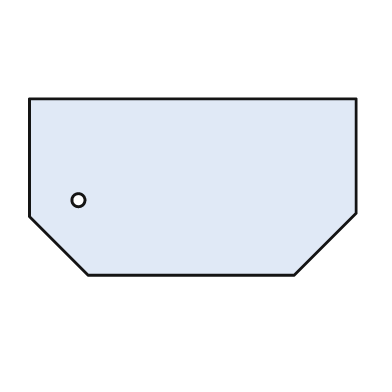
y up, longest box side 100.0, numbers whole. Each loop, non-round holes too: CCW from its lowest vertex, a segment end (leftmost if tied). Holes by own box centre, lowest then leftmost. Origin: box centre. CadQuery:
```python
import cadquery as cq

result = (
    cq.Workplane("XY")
    .moveTo(-32.0, -27.0)
    .lineTo(31.0, -27.0)
    .lineTo(50.0, -8.0)
    .lineTo(50.0, 27.0)
    .lineTo(-50.0, 27.0)
    .lineTo(-50.0, -9.0)
    .close()
    .moveTo(-35.0, -4.0)
    .circle(2.0)
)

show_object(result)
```